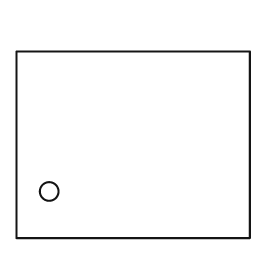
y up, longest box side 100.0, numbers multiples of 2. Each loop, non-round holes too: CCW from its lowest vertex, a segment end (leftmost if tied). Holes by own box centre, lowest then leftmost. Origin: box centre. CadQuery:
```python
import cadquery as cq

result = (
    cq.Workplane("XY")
    .moveTo(-50.0, -40.0)
    .lineTo(50.0, -40.0)
    .lineTo(50.0, 40.0)
    .lineTo(-50.0, 40.0)
    .close()
    .moveTo(-36.0, -20.0)
    .circle(4.0)
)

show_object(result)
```